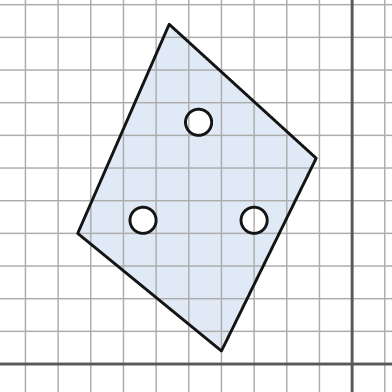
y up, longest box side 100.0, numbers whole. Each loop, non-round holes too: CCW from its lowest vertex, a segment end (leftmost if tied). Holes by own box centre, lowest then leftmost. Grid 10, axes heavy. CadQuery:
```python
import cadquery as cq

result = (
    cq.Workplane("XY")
    .moveTo(-40.0, 4.0)
    .lineTo(-11.0, 63.0)
    .lineTo(-56.0, 104.0)
    .lineTo(-84.0, 40.0)
    .close()
    .moveTo(-64.0, 44.0)
    .circle(4.0)
    .moveTo(-30.0, 44.0)
    .circle(4.0)
    .moveTo(-47.0, 74.0)
    .circle(4.0)
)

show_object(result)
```